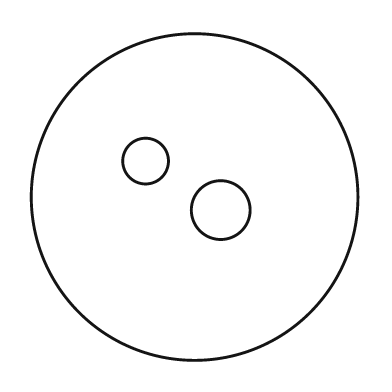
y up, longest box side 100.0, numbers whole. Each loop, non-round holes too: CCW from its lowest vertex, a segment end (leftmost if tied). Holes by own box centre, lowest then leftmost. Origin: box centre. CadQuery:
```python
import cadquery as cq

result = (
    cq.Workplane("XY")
    .moveTo(0.0, 0.0)
    .circle(50.0)
    .moveTo(8.0, -4.0)
    .circle(9.0)
    .moveTo(-15.0, 11.0)
    .circle(7.0)
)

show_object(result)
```